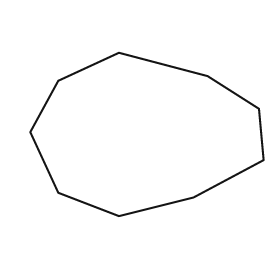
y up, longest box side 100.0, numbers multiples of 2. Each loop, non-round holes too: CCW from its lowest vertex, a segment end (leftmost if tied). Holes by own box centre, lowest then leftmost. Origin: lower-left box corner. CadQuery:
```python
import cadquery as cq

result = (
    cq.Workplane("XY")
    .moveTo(38.0, 0.0)
    .lineTo(70.0, 8.0)
    .lineTo(100.0, 24.0)
    .lineTo(98.0, 46.0)
    .lineTo(76.0, 60.0)
    .lineTo(38.0, 70.0)
    .lineTo(12.0, 58.0)
    .lineTo(0.0, 36.0)
    .lineTo(12.0, 10.0)
    .close()
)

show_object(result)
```